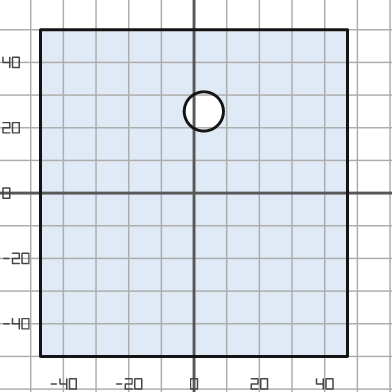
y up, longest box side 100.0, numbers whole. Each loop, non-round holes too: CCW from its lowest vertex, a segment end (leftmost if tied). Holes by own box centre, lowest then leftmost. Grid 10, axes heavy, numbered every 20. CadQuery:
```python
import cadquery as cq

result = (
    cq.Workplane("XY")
    .moveTo(-47.0, -50.0)
    .lineTo(47.0, -50.0)
    .lineTo(47.0, 50.0)
    .lineTo(-47.0, 50.0)
    .close()
    .moveTo(3.0, 25.0)
    .circle(6.0)
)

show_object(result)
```